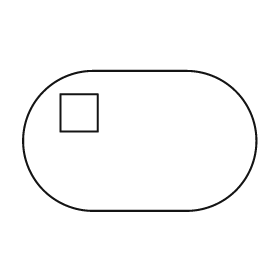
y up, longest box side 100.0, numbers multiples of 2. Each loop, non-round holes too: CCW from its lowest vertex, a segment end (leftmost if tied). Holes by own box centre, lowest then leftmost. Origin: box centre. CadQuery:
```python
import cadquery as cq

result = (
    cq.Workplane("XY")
    .moveTo(-20.0, -30.0)
    .lineTo(20.0, -30.0)
    .threePointArc((50.0, 0.0), (20.0, 30.0))
    .lineTo(-20.0, 30.0)
    .threePointArc((-50.0, 0.0), (-20.0, -30.0))
    .close()
    .moveTo(-34.0, 4.0)
    .lineTo(-18.0, 4.0)
    .lineTo(-18.0, 20.0)
    .lineTo(-34.0, 20.0)
    .close()
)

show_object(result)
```